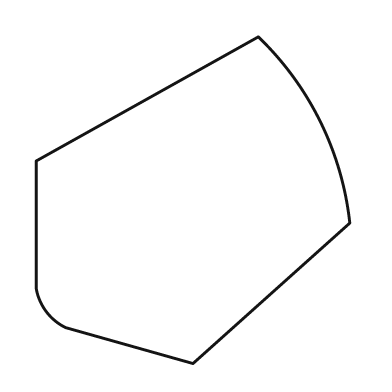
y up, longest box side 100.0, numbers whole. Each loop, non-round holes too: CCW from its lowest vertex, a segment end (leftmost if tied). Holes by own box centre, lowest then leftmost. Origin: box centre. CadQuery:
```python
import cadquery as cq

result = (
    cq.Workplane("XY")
    .moveTo(0.0, -50.0)
    .lineTo(48.0, -7.0)
    .threePointArc((39.0, 24.0), (20.0, 50.0))
    .lineTo(-48.0, 12.0)
    .lineTo(-48.0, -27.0)
    .threePointArc((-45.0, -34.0), (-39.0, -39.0))
    .close()
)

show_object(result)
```